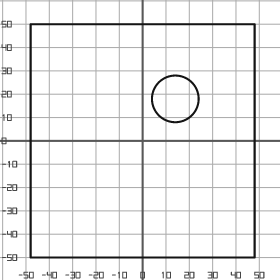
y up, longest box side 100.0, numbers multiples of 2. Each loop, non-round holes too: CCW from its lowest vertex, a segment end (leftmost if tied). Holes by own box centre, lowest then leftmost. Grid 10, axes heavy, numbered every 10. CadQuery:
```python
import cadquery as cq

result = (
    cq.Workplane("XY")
    .moveTo(-48.0, -50.0)
    .lineTo(48.0, -50.0)
    .lineTo(48.0, 50.0)
    .lineTo(-48.0, 50.0)
    .close()
    .moveTo(14.0, 18.0)
    .circle(10.0)
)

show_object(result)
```